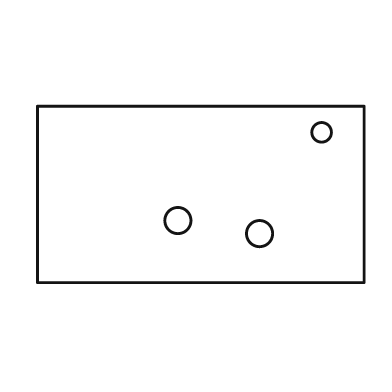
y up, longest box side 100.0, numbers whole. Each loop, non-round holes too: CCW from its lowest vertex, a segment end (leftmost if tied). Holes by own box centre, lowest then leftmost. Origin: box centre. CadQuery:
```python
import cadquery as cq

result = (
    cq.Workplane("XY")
    .moveTo(-50.0, -27.0)
    .lineTo(50.0, -27.0)
    .lineTo(50.0, 27.0)
    .lineTo(-50.0, 27.0)
    .close()
    .moveTo(18.0, -12.0)
    .circle(4.0)
    .moveTo(-7.0, -8.0)
    .circle(4.0)
    .moveTo(37.0, 19.0)
    .circle(3.0)
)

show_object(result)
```